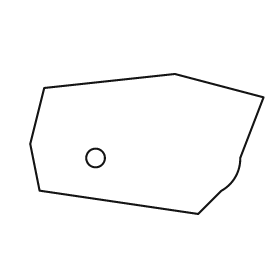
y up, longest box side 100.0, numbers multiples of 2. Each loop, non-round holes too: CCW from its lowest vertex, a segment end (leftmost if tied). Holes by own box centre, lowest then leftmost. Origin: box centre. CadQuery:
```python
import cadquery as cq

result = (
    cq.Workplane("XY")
    .moveTo(22.0, -30.0)
    .lineTo(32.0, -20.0)
    .threePointArc((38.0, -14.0), (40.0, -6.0))
    .lineTo(50.0, 20.0)
    .lineTo(12.0, 30.0)
    .lineTo(-44.0, 24.0)
    .lineTo(-50.0, 0.0)
    .lineTo(-46.0, -20.0)
    .close()
    .moveTo(-22.0, -6.0)
    .circle(4.0)
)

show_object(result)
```